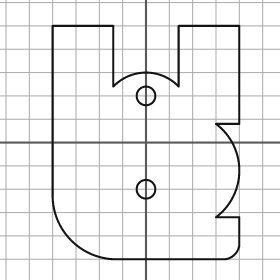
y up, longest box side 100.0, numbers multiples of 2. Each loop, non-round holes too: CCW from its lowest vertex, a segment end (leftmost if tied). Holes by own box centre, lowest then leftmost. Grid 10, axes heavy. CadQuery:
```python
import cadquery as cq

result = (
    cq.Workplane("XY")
    .moveTo(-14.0, -50.0)
    .lineTo(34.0, -50.0)
    .threePointArc((38.0, -48.0), (40.0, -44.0))
    .lineTo(40.0, -32.0)
    .lineTo(30.0, -32.0)
    .threePointArc((40.0, -12.0), (30.0, 8.0))
    .lineTo(40.0, 8.0)
    .lineTo(40.0, 50.0)
    .lineTo(14.0, 50.0)
    .lineTo(14.0, 24.0)
    .threePointArc((0.0, 30.0), (-14.0, 24.0))
    .lineTo(-14.0, 50.0)
    .lineTo(-40.0, 50.0)
    .lineTo(-40.0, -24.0)
    .threePointArc((-32.0, -42.0), (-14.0, -50.0))
    .close()
    .moveTo(0.0, -20.0)
    .circle(4.0)
    .moveTo(0.0, 20.0)
    .circle(4.0)
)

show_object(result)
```